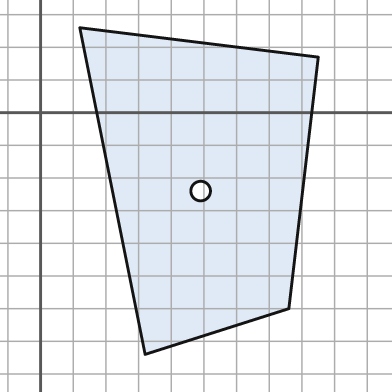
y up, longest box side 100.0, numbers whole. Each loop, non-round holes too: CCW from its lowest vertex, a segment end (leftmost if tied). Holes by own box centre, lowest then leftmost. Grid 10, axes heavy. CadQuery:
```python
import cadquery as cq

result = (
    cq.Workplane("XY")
    .moveTo(32.0, -74.0)
    .lineTo(76.0, -60.0)
    .lineTo(85.0, 17.0)
    .lineTo(12.0, 26.0)
    .close()
    .moveTo(49.0, -24.0)
    .circle(3.0)
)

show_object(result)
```